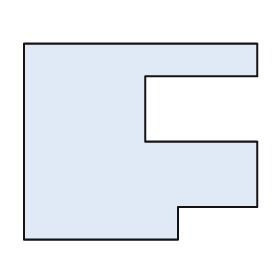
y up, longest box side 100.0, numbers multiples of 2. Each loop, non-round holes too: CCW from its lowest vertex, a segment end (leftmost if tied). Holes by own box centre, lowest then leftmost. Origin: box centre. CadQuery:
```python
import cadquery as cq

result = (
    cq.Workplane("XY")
    .moveTo(-50.0, -42.0)
    .lineTo(16.0, -42.0)
    .lineTo(16.0, -28.0)
    .lineTo(50.0, -28.0)
    .lineTo(50.0, 0.0)
    .lineTo(2.0, 0.0)
    .lineTo(2.0, 28.0)
    .lineTo(50.0, 28.0)
    .lineTo(50.0, 42.0)
    .lineTo(-50.0, 42.0)
    .close()
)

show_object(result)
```